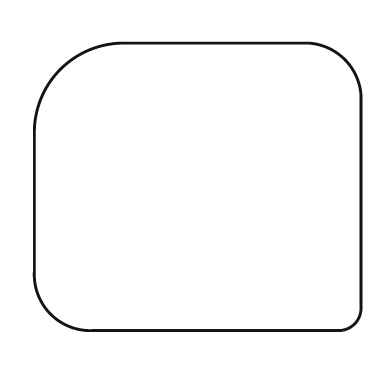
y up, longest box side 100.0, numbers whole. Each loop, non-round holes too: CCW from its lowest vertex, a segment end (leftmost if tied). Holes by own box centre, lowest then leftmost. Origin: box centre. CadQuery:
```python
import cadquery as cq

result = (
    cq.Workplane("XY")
    .moveTo(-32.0, -44.0)
    .lineTo(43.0, -44.0)
    .threePointArc((48.0, -42.0), (50.0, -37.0))
    .lineTo(50.0, 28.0)
    .threePointArc((45.0, 39.0), (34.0, 44.0))
    .lineTo(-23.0, 44.0)
    .threePointArc((-42.0, 36.0), (-50.0, 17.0))
    .lineTo(-50.0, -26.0)
    .threePointArc((-45.0, -39.0), (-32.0, -44.0))
    .close()
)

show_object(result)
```